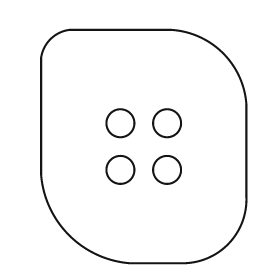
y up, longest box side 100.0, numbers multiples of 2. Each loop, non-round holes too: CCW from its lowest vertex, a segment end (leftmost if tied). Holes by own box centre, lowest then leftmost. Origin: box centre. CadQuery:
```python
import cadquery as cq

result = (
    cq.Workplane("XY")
    .moveTo(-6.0, -50.0)
    .lineTo(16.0, -50.0)
    .threePointArc((36.0, -42.0), (44.0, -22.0))
    .lineTo(44.0, 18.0)
    .threePointArc((34.0, 40.0), (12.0, 50.0))
    .lineTo(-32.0, 50.0)
    .threePointArc((-40.0, 46.0), (-44.0, 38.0))
    .lineTo(-44.0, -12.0)
    .threePointArc((-32.0, -38.0), (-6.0, -50.0))
    .close()
    .moveTo(-10.0, -10.0)
    .circle(6.0)
    .moveTo(10.0, -10.0)
    .circle(6.0)
    .moveTo(-10.0, 10.0)
    .circle(6.0)
    .moveTo(10.0, 10.0)
    .circle(6.0)
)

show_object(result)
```